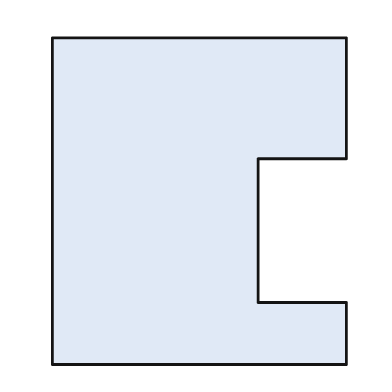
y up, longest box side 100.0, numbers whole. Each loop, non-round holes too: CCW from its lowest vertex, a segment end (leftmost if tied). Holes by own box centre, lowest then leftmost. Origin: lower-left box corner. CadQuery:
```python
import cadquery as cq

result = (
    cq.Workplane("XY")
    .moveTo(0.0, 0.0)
    .lineTo(90.0, 0.0)
    .lineTo(90.0, 19.0)
    .lineTo(63.0, 19.0)
    .lineTo(63.0, 63.0)
    .lineTo(90.0, 63.0)
    .lineTo(90.0, 100.0)
    .lineTo(0.0, 100.0)
    .close()
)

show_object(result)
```